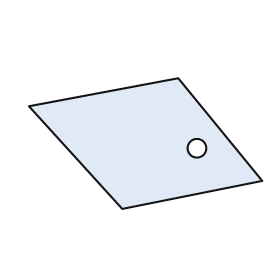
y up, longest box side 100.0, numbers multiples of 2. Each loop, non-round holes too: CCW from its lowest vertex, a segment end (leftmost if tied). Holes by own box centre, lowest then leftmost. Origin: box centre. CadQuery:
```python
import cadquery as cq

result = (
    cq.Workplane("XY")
    .moveTo(-10.0, -28.0)
    .lineTo(50.0, -16.0)
    .lineTo(14.0, 28.0)
    .lineTo(-50.0, 16.0)
    .close()
    .moveTo(22.0, -2.0)
    .circle(4.0)
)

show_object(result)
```